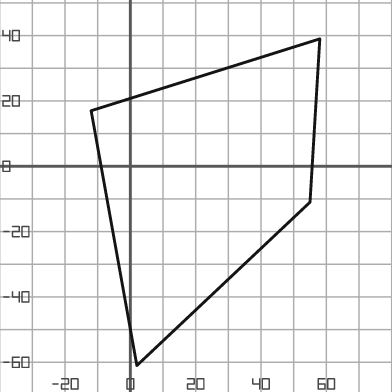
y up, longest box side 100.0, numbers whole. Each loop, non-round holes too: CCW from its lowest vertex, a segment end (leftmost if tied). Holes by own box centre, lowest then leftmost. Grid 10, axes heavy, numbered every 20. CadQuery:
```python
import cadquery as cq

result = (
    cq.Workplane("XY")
    .moveTo(2.0, -61.0)
    .lineTo(55.0, -11.0)
    .lineTo(58.0, 39.0)
    .lineTo(-12.0, 17.0)
    .close()
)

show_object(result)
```